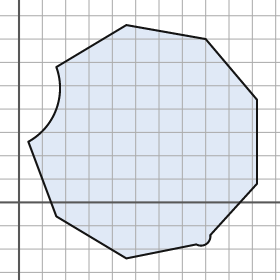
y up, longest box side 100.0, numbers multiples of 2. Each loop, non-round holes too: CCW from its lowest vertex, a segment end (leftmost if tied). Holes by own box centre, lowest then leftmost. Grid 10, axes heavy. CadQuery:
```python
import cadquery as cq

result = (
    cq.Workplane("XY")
    .moveTo(46.0, -24.0)
    .lineTo(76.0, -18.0)
    .threePointArc((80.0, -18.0), (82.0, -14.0))
    .lineTo(102.0, 8.0)
    .lineTo(102.0, 44.0)
    .lineTo(80.0, 70.0)
    .lineTo(46.0, 76.0)
    .lineTo(16.0, 58.0)
    .threePointArc((16.0, 40.0), (4.0, 26.0))
    .lineTo(16.0, -6.0)
    .close()
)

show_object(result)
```